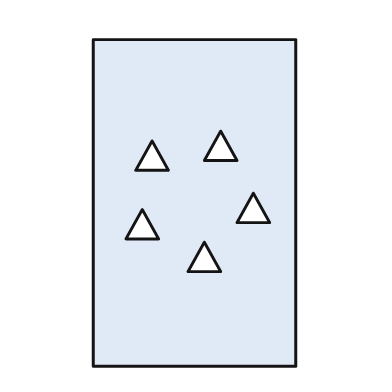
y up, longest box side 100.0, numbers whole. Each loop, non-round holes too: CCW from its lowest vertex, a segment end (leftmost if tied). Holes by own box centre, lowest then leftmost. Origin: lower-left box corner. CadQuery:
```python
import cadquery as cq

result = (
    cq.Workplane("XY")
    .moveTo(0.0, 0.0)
    .lineTo(62.0, 0.0)
    .lineTo(62.0, 100.0)
    .lineTo(0.0, 100.0)
    .close()
    .moveTo(29.0, 29.0)
    .lineTo(39.0, 29.0)
    .lineTo(34.0, 38.0)
    .close()
    .moveTo(10.0, 39.0)
    .lineTo(20.0, 39.0)
    .lineTo(15.0, 48.0)
    .close()
    .moveTo(44.0, 44.0)
    .lineTo(54.0, 44.0)
    .lineTo(49.0, 53.0)
    .close()
    .moveTo(13.0, 60.0)
    .lineTo(23.0, 60.0)
    .lineTo(18.0, 69.0)
    .close()
    .moveTo(34.0, 63.0)
    .lineTo(44.0, 63.0)
    .lineTo(39.0, 72.0)
    .close()
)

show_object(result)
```